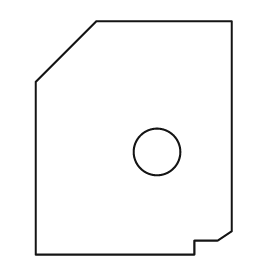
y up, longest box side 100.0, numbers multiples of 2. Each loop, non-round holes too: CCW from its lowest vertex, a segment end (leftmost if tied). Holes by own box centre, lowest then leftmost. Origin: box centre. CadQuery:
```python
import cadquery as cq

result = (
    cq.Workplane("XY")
    .moveTo(-42.0, -50.0)
    .lineTo(26.0, -50.0)
    .lineTo(26.0, -44.0)
    .lineTo(36.0, -44.0)
    .lineTo(42.0, -40.0)
    .lineTo(42.0, 50.0)
    .lineTo(-16.0, 50.0)
    .lineTo(-42.0, 24.0)
    .close()
    .moveTo(10.0, -6.0)
    .circle(10.0)
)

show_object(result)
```